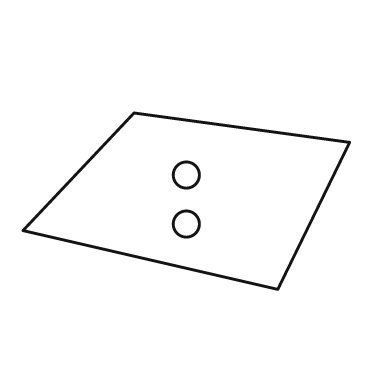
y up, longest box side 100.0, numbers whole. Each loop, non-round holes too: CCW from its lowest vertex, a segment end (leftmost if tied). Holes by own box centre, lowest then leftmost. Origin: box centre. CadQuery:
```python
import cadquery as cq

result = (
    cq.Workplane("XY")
    .moveTo(28.0, -27.0)
    .lineTo(50.0, 18.0)
    .lineTo(-16.0, 27.0)
    .lineTo(-50.0, -9.0)
    .close()
    .moveTo(0.0, -7.0)
    .circle(4.0)
    .moveTo(0.0, 8.0)
    .circle(4.0)
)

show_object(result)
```